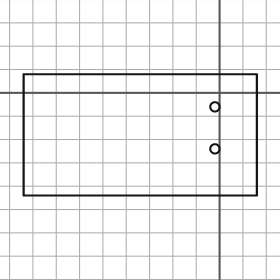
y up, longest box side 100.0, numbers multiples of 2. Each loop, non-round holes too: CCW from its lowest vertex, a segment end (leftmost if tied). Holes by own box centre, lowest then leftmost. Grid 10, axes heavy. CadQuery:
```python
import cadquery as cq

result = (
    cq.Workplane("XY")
    .moveTo(-84.0, -44.0)
    .lineTo(16.0, -44.0)
    .lineTo(16.0, 8.0)
    .lineTo(-84.0, 8.0)
    .close()
    .moveTo(-2.0, -24.0)
    .circle(2.0)
    .moveTo(-2.0, -6.0)
    .circle(2.0)
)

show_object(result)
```